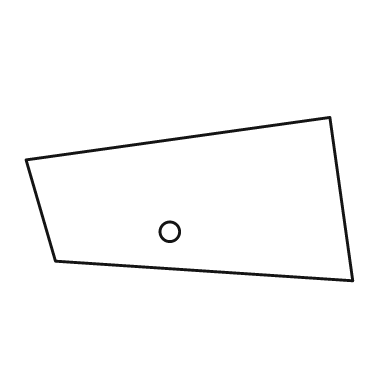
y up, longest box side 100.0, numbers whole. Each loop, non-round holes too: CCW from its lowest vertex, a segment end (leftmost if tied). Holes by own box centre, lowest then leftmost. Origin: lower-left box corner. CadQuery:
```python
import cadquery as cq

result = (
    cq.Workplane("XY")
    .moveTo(100.0, 0.0)
    .lineTo(93.0, 50.0)
    .lineTo(0.0, 37.0)
    .lineTo(9.0, 6.0)
    .close()
    .moveTo(44.0, 15.0)
    .circle(3.0)
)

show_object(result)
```